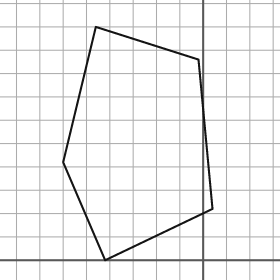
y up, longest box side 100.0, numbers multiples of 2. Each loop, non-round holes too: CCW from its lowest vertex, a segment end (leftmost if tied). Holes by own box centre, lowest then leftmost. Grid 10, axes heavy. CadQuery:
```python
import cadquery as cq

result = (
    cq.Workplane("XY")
    .moveTo(-42.0, 0.0)
    .lineTo(4.0, 22.0)
    .lineTo(-2.0, 86.0)
    .lineTo(-46.0, 100.0)
    .lineTo(-60.0, 42.0)
    .close()
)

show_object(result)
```